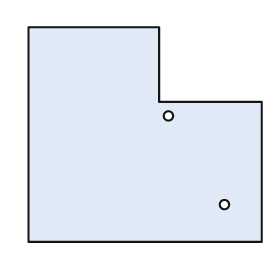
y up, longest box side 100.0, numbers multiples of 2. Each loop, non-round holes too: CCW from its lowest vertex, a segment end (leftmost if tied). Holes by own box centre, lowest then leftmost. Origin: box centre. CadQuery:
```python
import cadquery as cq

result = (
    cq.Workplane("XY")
    .moveTo(-50.0, -46.0)
    .lineTo(50.0, -46.0)
    .lineTo(50.0, 14.0)
    .lineTo(6.0, 14.0)
    .lineTo(6.0, 46.0)
    .lineTo(-50.0, 46.0)
    .close()
    .moveTo(34.0, -30.0)
    .circle(2.0)
    .moveTo(10.0, 8.0)
    .circle(2.0)
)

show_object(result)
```